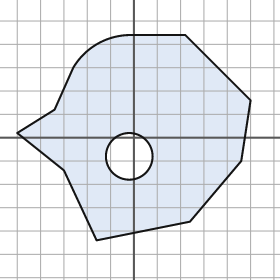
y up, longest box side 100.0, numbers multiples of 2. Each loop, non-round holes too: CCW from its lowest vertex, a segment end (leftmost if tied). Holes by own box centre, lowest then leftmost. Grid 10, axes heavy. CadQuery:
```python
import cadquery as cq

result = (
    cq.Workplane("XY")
    .moveTo(-16.0, -44.0)
    .lineTo(24.0, -36.0)
    .lineTo(46.0, -10.0)
    .lineTo(50.0, 16.0)
    .lineTo(22.0, 44.0)
    .lineTo(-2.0, 44.0)
    .threePointArc((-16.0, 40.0), (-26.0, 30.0))
    .lineTo(-34.0, 12.0)
    .lineTo(-50.0, 2.0)
    .lineTo(-30.0, -14.0)
    .close()
    .moveTo(-2.0, -8.0)
    .circle(10.0)
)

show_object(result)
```